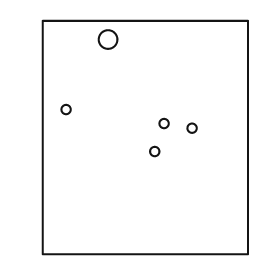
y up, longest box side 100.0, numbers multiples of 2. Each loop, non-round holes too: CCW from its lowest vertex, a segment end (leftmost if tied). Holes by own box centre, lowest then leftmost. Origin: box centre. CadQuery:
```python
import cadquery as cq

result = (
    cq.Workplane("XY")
    .moveTo(-44.0, -50.0)
    .lineTo(44.0, -50.0)
    .lineTo(44.0, 50.0)
    .lineTo(-44.0, 50.0)
    .close()
    .moveTo(4.0, -6.0)
    .circle(2.0)
    .moveTo(20.0, 4.0)
    .circle(2.0)
    .moveTo(8.0, 6.0)
    .circle(2.0)
    .moveTo(-34.0, 12.0)
    .circle(2.0)
    .moveTo(-16.0, 42.0)
    .circle(4.0)
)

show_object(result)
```